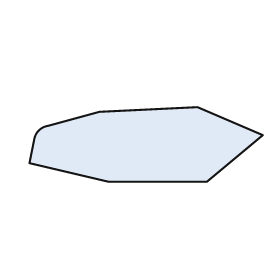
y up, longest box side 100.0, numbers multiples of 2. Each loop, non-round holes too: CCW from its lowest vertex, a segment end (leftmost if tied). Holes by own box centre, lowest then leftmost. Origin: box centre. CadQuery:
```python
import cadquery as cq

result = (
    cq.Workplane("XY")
    .moveTo(-16.0, -16.0)
    .lineTo(26.0, -16.0)
    .lineTo(50.0, 4.0)
    .lineTo(22.0, 16.0)
    .lineTo(-20.0, 14.0)
    .lineTo(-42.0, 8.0)
    .threePointArc((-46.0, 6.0), (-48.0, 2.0))
    .lineTo(-50.0, -8.0)
    .close()
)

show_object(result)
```